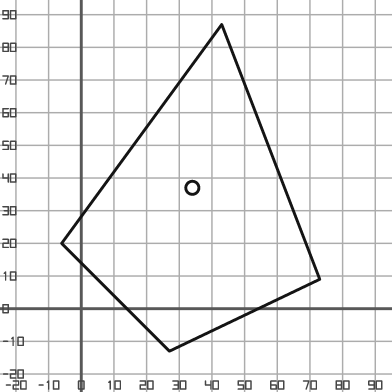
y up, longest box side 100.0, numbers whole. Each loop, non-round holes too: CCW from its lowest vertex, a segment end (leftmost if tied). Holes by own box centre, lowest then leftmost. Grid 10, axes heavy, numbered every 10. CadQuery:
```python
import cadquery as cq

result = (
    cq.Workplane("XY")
    .moveTo(27.0, -13.0)
    .lineTo(73.0, 9.0)
    .lineTo(43.0, 87.0)
    .lineTo(-6.0, 20.0)
    .close()
    .moveTo(34.0, 37.0)
    .circle(2.0)
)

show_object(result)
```